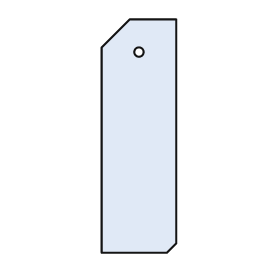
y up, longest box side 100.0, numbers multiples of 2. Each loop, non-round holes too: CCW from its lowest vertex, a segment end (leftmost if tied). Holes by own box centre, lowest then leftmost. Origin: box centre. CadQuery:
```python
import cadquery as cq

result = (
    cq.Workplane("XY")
    .moveTo(-16.0, -50.0)
    .lineTo(12.0, -50.0)
    .lineTo(16.0, -46.0)
    .lineTo(16.0, 50.0)
    .lineTo(-4.0, 50.0)
    .lineTo(-16.0, 38.0)
    .close()
    .moveTo(0.0, 36.0)
    .circle(2.0)
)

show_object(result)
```